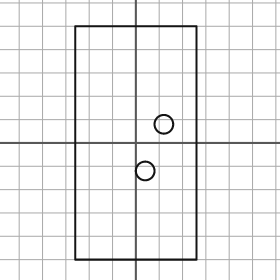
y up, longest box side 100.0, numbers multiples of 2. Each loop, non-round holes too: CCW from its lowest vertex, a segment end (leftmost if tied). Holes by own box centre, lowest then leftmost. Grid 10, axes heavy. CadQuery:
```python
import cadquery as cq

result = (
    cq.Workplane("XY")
    .moveTo(-26.0, -50.0)
    .lineTo(26.0, -50.0)
    .lineTo(26.0, 50.0)
    .lineTo(-26.0, 50.0)
    .close()
    .moveTo(4.0, -12.0)
    .circle(4.0)
    .moveTo(12.0, 8.0)
    .circle(4.0)
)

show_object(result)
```